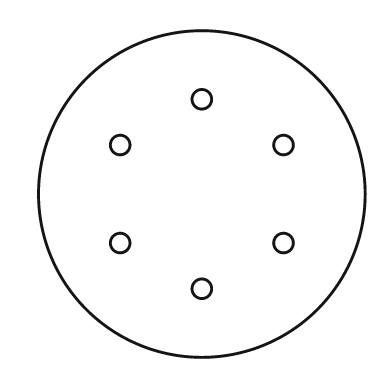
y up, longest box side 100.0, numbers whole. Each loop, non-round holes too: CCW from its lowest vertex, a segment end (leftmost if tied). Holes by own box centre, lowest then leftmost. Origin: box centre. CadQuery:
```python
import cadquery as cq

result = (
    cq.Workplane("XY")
    .moveTo(0.0, 0.0)
    .circle(50.0)
    .moveTo(0.0, -29.0)
    .circle(3.0)
    .moveTo(-25.0, -15.0)
    .circle(3.0)
    .moveTo(25.0, -15.0)
    .circle(3.0)
    .moveTo(-25.0, 15.0)
    .circle(3.0)
    .moveTo(25.0, 15.0)
    .circle(3.0)
    .moveTo(0.0, 29.0)
    .circle(3.0)
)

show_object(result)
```